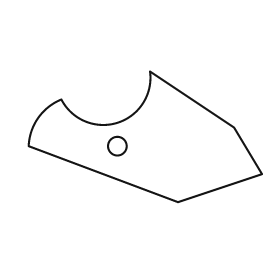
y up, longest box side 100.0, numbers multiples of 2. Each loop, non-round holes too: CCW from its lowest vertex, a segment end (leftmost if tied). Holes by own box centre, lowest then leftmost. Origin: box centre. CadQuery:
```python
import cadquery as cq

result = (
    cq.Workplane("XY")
    .moveTo(14.0, -28.0)
    .lineTo(50.0, -16.0)
    .lineTo(38.0, 4.0)
    .lineTo(2.0, 28.0)
    .threePointArc((-12.0, 6.0), (-36.0, 16.0))
    .threePointArc((-46.0, 8.0), (-50.0, -4.0))
    .close()
    .moveTo(-12.0, -4.0)
    .circle(4.0)
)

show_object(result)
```